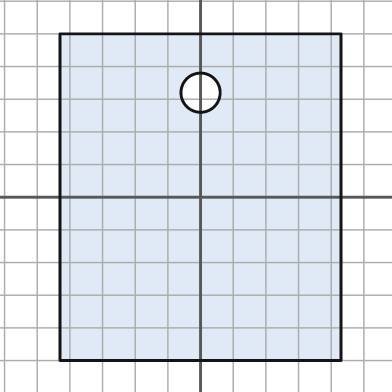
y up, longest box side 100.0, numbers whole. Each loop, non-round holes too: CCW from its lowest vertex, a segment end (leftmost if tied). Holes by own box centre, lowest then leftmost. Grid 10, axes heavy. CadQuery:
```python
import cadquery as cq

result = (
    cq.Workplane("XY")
    .moveTo(-43.0, -50.0)
    .lineTo(43.0, -50.0)
    .lineTo(43.0, 50.0)
    .lineTo(-43.0, 50.0)
    .close()
    .moveTo(0.0, 32.0)
    .circle(6.0)
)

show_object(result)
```